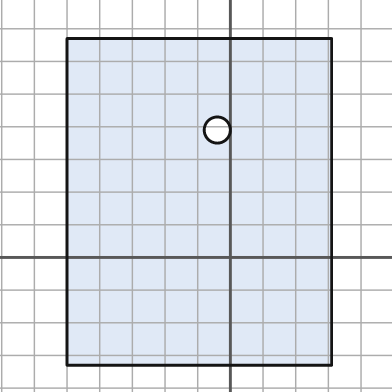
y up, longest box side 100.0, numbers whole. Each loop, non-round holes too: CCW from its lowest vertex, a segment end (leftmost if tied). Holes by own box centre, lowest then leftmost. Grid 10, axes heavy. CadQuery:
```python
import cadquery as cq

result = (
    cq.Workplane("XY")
    .moveTo(-50.0, -33.0)
    .lineTo(31.0, -33.0)
    .lineTo(31.0, 67.0)
    .lineTo(-50.0, 67.0)
    .close()
    .moveTo(-4.0, 39.0)
    .circle(4.0)
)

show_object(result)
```